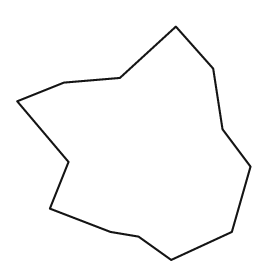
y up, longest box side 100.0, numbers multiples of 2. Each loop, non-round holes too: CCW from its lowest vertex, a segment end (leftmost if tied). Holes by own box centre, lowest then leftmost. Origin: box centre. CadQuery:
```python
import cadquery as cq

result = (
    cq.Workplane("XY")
    .moveTo(16.0, -50.0)
    .lineTo(42.0, -38.0)
    .lineTo(50.0, -10.0)
    .lineTo(38.0, 6.0)
    .lineTo(34.0, 32.0)
    .lineTo(18.0, 50.0)
    .lineTo(-6.0, 28.0)
    .lineTo(-30.0, 26.0)
    .lineTo(-50.0, 18.0)
    .lineTo(-28.0, -8.0)
    .lineTo(-36.0, -28.0)
    .lineTo(-10.0, -38.0)
    .lineTo(2.0, -40.0)
    .close()
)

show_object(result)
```